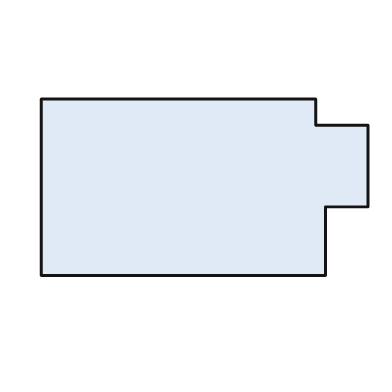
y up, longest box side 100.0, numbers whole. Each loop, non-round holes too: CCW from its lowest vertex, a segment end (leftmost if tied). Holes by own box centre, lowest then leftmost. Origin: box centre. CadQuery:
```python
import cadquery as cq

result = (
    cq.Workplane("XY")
    .moveTo(-50.0, -27.0)
    .lineTo(37.0, -27.0)
    .lineTo(37.0, -6.0)
    .lineTo(50.0, -6.0)
    .lineTo(50.0, 19.0)
    .lineTo(34.0, 19.0)
    .lineTo(34.0, 27.0)
    .lineTo(-50.0, 27.0)
    .close()
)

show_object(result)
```